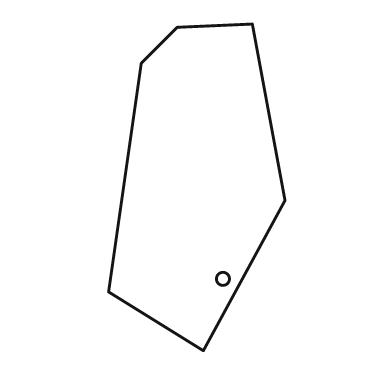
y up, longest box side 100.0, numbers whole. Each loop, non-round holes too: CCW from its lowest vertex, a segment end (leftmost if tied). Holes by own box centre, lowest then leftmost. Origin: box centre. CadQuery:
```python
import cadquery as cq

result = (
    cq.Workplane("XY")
    .moveTo(2.0, -50.0)
    .lineTo(27.0, -4.0)
    .lineTo(17.0, 50.0)
    .lineTo(-6.0, 49.0)
    .lineTo(-17.0, 38.0)
    .lineTo(-27.0, -32.0)
    .close()
    .moveTo(8.0, -28.0)
    .circle(2.0)
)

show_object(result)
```